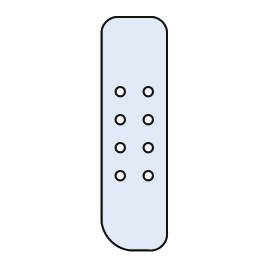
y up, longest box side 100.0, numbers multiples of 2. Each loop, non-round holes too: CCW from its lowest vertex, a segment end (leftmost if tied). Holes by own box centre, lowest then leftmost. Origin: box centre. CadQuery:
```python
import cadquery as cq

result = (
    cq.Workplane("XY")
    .moveTo(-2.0, -50.0)
    .lineTo(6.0, -50.0)
    .threePointArc((12.0, -48.0), (14.0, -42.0))
    .lineTo(14.0, 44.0)
    .threePointArc((12.0, 48.0), (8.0, 50.0))
    .lineTo(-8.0, 50.0)
    .threePointArc((-12.0, 48.0), (-14.0, 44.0))
    .lineTo(-14.0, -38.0)
    .threePointArc((-10.0, -46.0), (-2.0, -50.0))
    .close()
    .moveTo(-6.0, -18.0)
    .circle(2.0)
    .moveTo(6.0, -18.0)
    .circle(2.0)
    .moveTo(-6.0, -6.0)
    .circle(2.0)
    .moveTo(6.0, -6.0)
    .circle(2.0)
    .moveTo(-6.0, 6.0)
    .circle(2.0)
    .moveTo(6.0, 6.0)
    .circle(2.0)
    .moveTo(-6.0, 18.0)
    .circle(2.0)
    .moveTo(6.0, 18.0)
    .circle(2.0)
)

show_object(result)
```